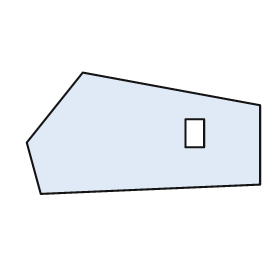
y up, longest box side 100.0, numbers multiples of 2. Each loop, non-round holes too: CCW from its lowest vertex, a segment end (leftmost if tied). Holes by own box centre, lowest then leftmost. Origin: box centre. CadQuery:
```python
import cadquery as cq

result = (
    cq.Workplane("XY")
    .moveTo(-44.0, -26.0)
    .lineTo(50.0, -22.0)
    .lineTo(50.0, 12.0)
    .lineTo(-26.0, 26.0)
    .lineTo(-50.0, -4.0)
    .close()
    .moveTo(18.0, -6.0)
    .lineTo(26.0, -6.0)
    .lineTo(26.0, 6.0)
    .lineTo(18.0, 6.0)
    .close()
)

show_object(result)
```